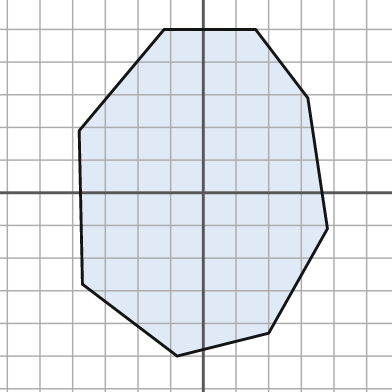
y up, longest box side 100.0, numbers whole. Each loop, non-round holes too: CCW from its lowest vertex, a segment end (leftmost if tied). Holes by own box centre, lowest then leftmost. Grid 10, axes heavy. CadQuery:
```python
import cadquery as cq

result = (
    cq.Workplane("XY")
    .moveTo(-8.0, -50.0)
    .lineTo(20.0, -43.0)
    .lineTo(38.0, -11.0)
    .lineTo(32.0, 29.0)
    .lineTo(16.0, 50.0)
    .lineTo(-12.0, 50.0)
    .lineTo(-38.0, 19.0)
    .lineTo(-37.0, -28.0)
    .close()
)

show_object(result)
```